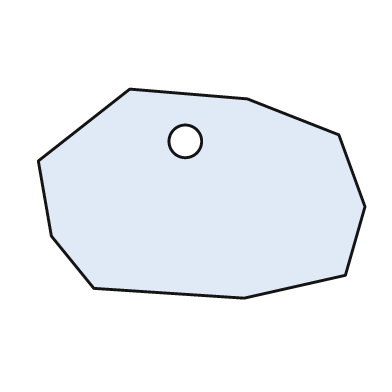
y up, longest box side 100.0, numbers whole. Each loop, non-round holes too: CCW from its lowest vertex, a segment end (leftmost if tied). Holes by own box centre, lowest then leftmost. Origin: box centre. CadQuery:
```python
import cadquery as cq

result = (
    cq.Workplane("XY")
    .moveTo(13.0, -32.0)
    .lineTo(44.0, -25.0)
    .lineTo(50.0, -4.0)
    .lineTo(42.0, 18.0)
    .lineTo(14.0, 29.0)
    .lineTo(-22.0, 32.0)
    .lineTo(-50.0, 10.0)
    .lineTo(-46.0, -13.0)
    .lineTo(-33.0, -29.0)
    .close()
    .moveTo(-5.0, 16.0)
    .circle(5.0)
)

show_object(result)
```